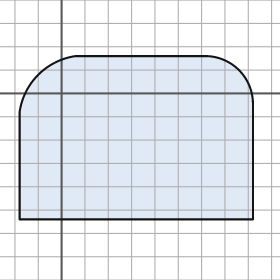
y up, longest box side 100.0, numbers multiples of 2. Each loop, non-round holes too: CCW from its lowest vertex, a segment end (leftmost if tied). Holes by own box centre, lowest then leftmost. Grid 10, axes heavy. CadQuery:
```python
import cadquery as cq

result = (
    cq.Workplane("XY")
    .moveTo(-18.0, -54.0)
    .lineTo(82.0, -54.0)
    .lineTo(82.0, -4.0)
    .threePointArc((76.0, 10.0), (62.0, 16.0))
    .lineTo(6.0, 16.0)
    .threePointArc((-10.0, 8.0), (-18.0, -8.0))
    .close()
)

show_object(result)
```